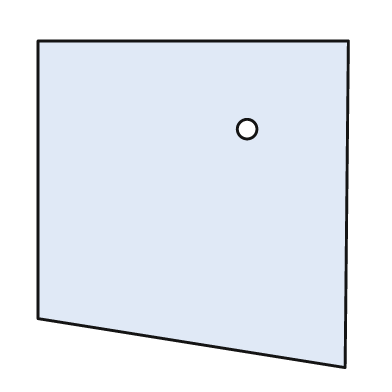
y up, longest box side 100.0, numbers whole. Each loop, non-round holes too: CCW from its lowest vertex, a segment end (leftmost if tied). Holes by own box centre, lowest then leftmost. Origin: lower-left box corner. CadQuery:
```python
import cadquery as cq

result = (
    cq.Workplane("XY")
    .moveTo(94.0, 0.0)
    .lineTo(95.0, 100.0)
    .lineTo(0.0, 100.0)
    .lineTo(0.0, 15.0)
    .close()
    .moveTo(64.0, 73.0)
    .circle(3.0)
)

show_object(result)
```